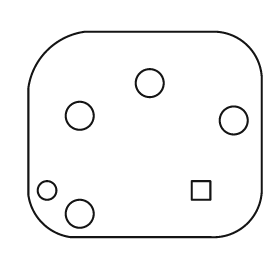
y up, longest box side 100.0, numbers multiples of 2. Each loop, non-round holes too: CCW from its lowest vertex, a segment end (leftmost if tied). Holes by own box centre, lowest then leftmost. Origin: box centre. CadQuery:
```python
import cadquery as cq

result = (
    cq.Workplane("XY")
    .moveTo(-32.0, -44.0)
    .lineTo(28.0, -44.0)
    .threePointArc((44.0, -38.0), (50.0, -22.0))
    .lineTo(50.0, 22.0)
    .threePointArc((44.0, 38.0), (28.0, 44.0))
    .lineTo(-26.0, 44.0)
    .threePointArc((-42.0, 36.0), (-50.0, 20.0))
    .lineTo(-50.0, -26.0)
    .threePointArc((-44.0, -38.0), (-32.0, -44.0))
    .close()
    .moveTo(-28.0, -34.0)
    .circle(6.0)
    .moveTo(-42.0, -24.0)
    .circle(4.0)
    .moveTo(20.0, -28.0)
    .lineTo(28.0, -28.0)
    .lineTo(28.0, -20.0)
    .lineTo(20.0, -20.0)
    .close()
    .moveTo(38.0, 6.0)
    .circle(6.0)
    .moveTo(-28.0, 8.0)
    .circle(6.0)
    .moveTo(2.0, 22.0)
    .circle(6.0)
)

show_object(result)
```